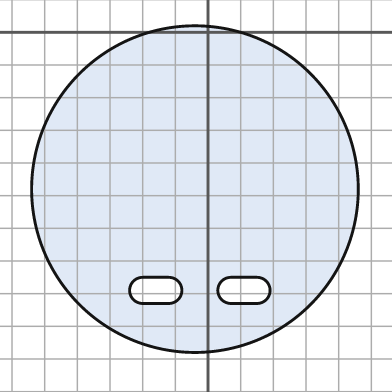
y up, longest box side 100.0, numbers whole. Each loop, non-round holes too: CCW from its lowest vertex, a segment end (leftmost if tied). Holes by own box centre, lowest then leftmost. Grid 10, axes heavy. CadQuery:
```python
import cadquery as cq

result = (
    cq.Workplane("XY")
    .moveTo(-4.0, -48.0)
    .circle(50.0)
    .moveTo(-20.0, -83.0)
    .lineTo(-12.0, -83.0)
    .threePointArc((-8.0, -79.0), (-12.0, -75.0))
    .lineTo(-20.0, -75.0)
    .threePointArc((-24.0, -79.0), (-20.0, -83.0))
    .close()
    .moveTo(7.0, -83.0)
    .lineTo(15.0, -83.0)
    .threePointArc((19.0, -79.0), (15.0, -75.0))
    .lineTo(7.0, -75.0)
    .threePointArc((3.0, -79.0), (7.0, -83.0))
    .close()
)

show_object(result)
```